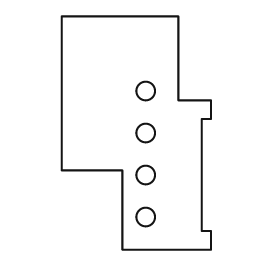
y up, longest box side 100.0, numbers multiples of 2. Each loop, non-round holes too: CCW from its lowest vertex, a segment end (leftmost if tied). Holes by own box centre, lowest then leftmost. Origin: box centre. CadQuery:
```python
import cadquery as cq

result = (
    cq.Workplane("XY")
    .moveTo(-6.0, -50.0)
    .lineTo(32.0, -50.0)
    .lineTo(32.0, -42.0)
    .lineTo(28.0, -42.0)
    .lineTo(28.0, 6.0)
    .lineTo(32.0, 6.0)
    .lineTo(32.0, 14.0)
    .lineTo(18.0, 14.0)
    .lineTo(18.0, 50.0)
    .lineTo(-32.0, 50.0)
    .lineTo(-32.0, -16.0)
    .lineTo(-6.0, -16.0)
    .close()
    .moveTo(4.0, -36.0)
    .circle(4.0)
    .moveTo(4.0, -18.0)
    .circle(4.0)
    .moveTo(4.0, 0.0)
    .circle(4.0)
    .moveTo(4.0, 18.0)
    .circle(4.0)
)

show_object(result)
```